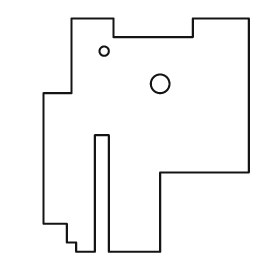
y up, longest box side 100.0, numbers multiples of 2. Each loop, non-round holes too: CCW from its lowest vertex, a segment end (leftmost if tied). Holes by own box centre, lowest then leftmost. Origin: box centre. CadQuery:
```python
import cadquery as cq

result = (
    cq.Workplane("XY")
    .moveTo(-30.0, -50.0)
    .lineTo(-22.0, -50.0)
    .lineTo(-22.0, 0.0)
    .lineTo(-16.0, 0.0)
    .lineTo(-16.0, -50.0)
    .lineTo(6.0, -50.0)
    .lineTo(6.0, -16.0)
    .lineTo(44.0, -16.0)
    .lineTo(44.0, 50.0)
    .lineTo(20.0, 50.0)
    .lineTo(20.0, 42.0)
    .lineTo(-14.0, 42.0)
    .lineTo(-14.0, 50.0)
    .lineTo(-32.0, 50.0)
    .lineTo(-32.0, 18.0)
    .lineTo(-44.0, 18.0)
    .lineTo(-44.0, -38.0)
    .lineTo(-34.0, -38.0)
    .lineTo(-34.0, -46.0)
    .lineTo(-30.0, -46.0)
    .close()
    .moveTo(6.0, 22.0)
    .circle(4.0)
    .moveTo(-18.0, 36.0)
    .circle(2.0)
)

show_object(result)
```